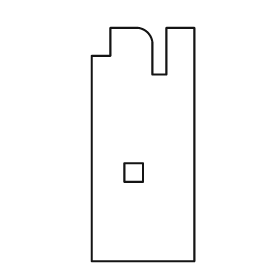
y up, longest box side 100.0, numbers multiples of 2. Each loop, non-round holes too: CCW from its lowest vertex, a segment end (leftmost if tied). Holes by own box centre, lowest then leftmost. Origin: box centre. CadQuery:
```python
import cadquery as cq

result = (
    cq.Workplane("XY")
    .moveTo(-22.0, -50.0)
    .lineTo(22.0, -50.0)
    .lineTo(22.0, 50.0)
    .lineTo(10.0, 50.0)
    .lineTo(10.0, 30.0)
    .lineTo(4.0, 30.0)
    .lineTo(4.0, 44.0)
    .threePointArc((2.0, 48.0), (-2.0, 50.0))
    .lineTo(-14.0, 50.0)
    .lineTo(-14.0, 38.0)
    .lineTo(-22.0, 38.0)
    .close()
    .moveTo(-8.0, -16.0)
    .lineTo(0.0, -16.0)
    .lineTo(0.0, -8.0)
    .lineTo(-8.0, -8.0)
    .close()
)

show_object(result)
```